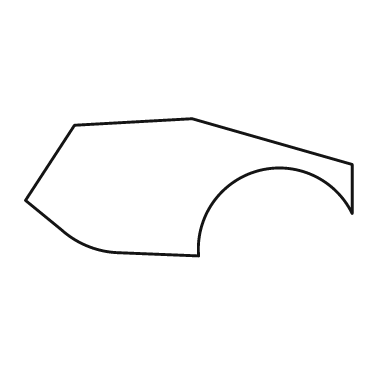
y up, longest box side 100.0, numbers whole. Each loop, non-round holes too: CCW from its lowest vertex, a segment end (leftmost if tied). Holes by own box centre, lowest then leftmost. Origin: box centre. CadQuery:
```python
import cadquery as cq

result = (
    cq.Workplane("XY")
    .moveTo(3.0, -21.0)
    .threePointArc((21.0, 5.0), (50.0, -8.0))
    .lineTo(50.0, 7.0)
    .lineTo(1.0, 21.0)
    .lineTo(-35.0, 19.0)
    .lineTo(-50.0, -4.0)
    .lineTo(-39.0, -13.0)
    .threePointArc((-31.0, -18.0), (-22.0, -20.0))
    .close()
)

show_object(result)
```